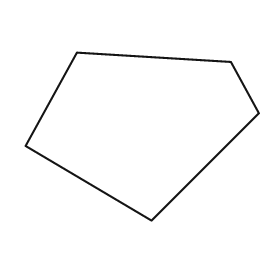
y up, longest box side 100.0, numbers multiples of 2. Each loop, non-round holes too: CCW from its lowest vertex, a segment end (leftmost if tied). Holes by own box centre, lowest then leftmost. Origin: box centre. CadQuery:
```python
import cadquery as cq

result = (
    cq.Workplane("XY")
    .moveTo(4.0, -36.0)
    .lineTo(50.0, 10.0)
    .lineTo(38.0, 32.0)
    .lineTo(-28.0, 36.0)
    .lineTo(-50.0, -4.0)
    .close()
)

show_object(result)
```